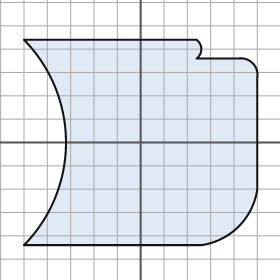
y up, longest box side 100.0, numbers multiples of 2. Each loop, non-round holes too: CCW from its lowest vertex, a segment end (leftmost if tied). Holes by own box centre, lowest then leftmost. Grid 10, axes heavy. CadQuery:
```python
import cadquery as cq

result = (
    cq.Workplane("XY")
    .moveTo(-50.0, -44.0)
    .lineTo(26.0, -44.0)
    .threePointArc((42.0, -36.0), (50.0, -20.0))
    .lineTo(50.0, 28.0)
    .threePointArc((48.0, 34.0), (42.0, 36.0))
    .lineTo(24.0, 36.0)
    .threePointArc((26.0, 40.0), (24.0, 44.0))
    .lineTo(-50.0, 44.0)
    .threePointArc((-32.0, 0.0), (-50.0, -44.0))
    .close()
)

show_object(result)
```